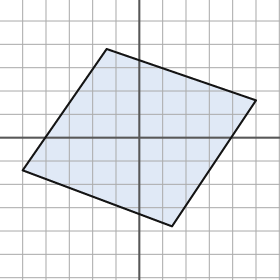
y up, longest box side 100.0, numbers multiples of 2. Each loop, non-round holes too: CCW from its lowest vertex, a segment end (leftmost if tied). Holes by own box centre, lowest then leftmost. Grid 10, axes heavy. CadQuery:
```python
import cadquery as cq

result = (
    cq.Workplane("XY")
    .moveTo(14.0, -38.0)
    .lineTo(50.0, 16.0)
    .lineTo(-14.0, 38.0)
    .lineTo(-50.0, -14.0)
    .close()
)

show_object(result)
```